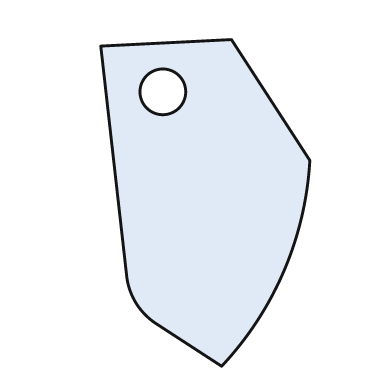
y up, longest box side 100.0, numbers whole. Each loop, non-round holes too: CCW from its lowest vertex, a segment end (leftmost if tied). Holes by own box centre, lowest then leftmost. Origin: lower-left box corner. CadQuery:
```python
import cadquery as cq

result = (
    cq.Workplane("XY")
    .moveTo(37.0, 0.0)
    .threePointArc((56.0, 29.0), (64.0, 63.0))
    .lineTo(40.0, 100.0)
    .lineTo(0.0, 98.0)
    .lineTo(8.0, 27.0)
    .threePointArc((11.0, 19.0), (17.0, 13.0))
    .close()
    .moveTo(19.0, 84.0)
    .circle(7.0)
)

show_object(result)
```